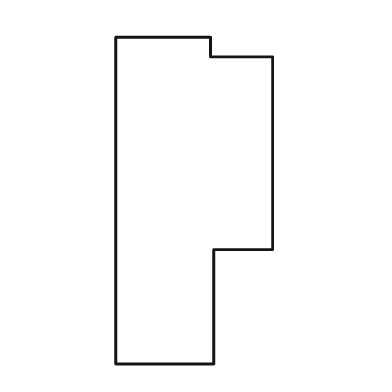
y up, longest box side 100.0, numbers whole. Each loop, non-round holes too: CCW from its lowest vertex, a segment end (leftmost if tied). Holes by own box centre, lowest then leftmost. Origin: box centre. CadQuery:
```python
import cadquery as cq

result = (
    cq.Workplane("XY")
    .moveTo(-24.0, -50.0)
    .lineTo(6.0, -50.0)
    .lineTo(6.0, -15.0)
    .lineTo(24.0, -15.0)
    .lineTo(24.0, 44.0)
    .lineTo(5.0, 44.0)
    .lineTo(5.0, 50.0)
    .lineTo(-24.0, 50.0)
    .close()
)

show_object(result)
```